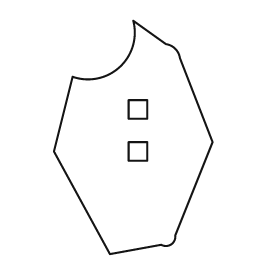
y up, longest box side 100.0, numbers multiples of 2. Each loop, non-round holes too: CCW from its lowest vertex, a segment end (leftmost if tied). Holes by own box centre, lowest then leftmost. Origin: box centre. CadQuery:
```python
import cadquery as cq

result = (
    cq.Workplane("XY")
    .moveTo(-10.0, -50.0)
    .lineTo(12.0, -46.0)
    .threePointArc((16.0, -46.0), (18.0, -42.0))
    .lineTo(34.0, -2.0)
    .lineTo(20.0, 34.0)
    .threePointArc((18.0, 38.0), (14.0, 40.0))
    .lineTo(0.0, 50.0)
    .threePointArc((-6.0, 30.0), (-26.0, 26.0))
    .lineTo(-34.0, -6.0)
    .close()
    .moveTo(-2.0, -10.0)
    .lineTo(6.0, -10.0)
    .lineTo(6.0, -2.0)
    .lineTo(-2.0, -2.0)
    .close()
    .moveTo(-2.0, 8.0)
    .lineTo(6.0, 8.0)
    .lineTo(6.0, 16.0)
    .lineTo(-2.0, 16.0)
    .close()
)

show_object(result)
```